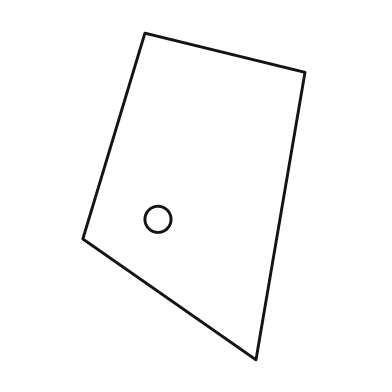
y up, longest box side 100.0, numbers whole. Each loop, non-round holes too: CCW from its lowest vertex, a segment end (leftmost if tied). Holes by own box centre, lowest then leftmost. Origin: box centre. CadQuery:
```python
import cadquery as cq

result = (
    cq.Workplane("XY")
    .moveTo(19.0, -50.0)
    .lineTo(34.0, 38.0)
    .lineTo(-15.0, 50.0)
    .lineTo(-34.0, -13.0)
    .close()
    .moveTo(-11.0, -7.0)
    .circle(4.0)
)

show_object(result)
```